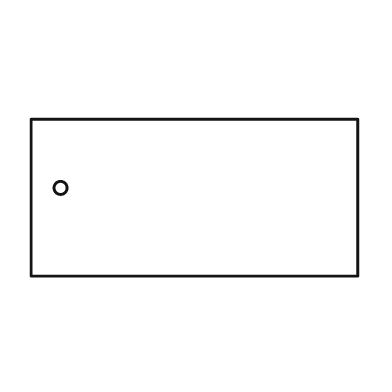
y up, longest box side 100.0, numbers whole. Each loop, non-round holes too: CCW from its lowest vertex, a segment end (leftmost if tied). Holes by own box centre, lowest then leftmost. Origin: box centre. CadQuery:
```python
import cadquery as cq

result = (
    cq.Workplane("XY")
    .moveTo(-50.0, -24.0)
    .lineTo(50.0, -24.0)
    .lineTo(50.0, 24.0)
    .lineTo(-50.0, 24.0)
    .close()
    .moveTo(-41.0, 3.0)
    .circle(2.0)
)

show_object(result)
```